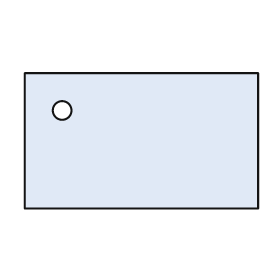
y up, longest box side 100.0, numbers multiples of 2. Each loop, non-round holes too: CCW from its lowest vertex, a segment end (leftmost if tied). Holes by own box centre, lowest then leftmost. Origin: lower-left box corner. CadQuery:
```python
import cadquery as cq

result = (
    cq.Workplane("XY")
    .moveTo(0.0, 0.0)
    .lineTo(100.0, 0.0)
    .lineTo(100.0, 58.0)
    .lineTo(0.0, 58.0)
    .close()
    .moveTo(16.0, 42.0)
    .circle(4.0)
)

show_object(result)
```